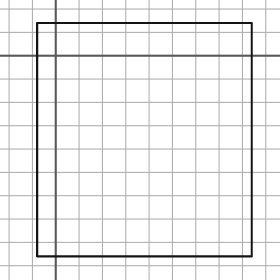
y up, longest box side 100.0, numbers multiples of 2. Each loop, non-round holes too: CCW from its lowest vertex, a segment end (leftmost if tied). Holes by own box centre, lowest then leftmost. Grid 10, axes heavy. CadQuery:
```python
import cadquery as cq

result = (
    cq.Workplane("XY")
    .moveTo(-8.0, -86.0)
    .lineTo(84.0, -86.0)
    .lineTo(84.0, 14.0)
    .lineTo(-8.0, 14.0)
    .close()
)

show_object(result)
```